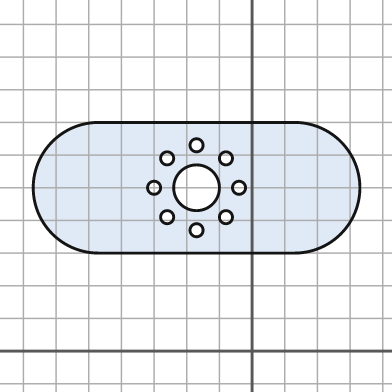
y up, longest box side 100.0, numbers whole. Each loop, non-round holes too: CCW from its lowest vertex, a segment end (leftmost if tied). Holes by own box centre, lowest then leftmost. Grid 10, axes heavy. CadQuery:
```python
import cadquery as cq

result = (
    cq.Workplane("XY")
    .moveTo(-47.0, 30.0)
    .lineTo(13.0, 30.0)
    .threePointArc((33.0, 50.0), (13.0, 70.0))
    .lineTo(-47.0, 70.0)
    .threePointArc((-67.0, 50.0), (-47.0, 30.0))
    .close()
    .moveTo(-17.0, 37.0)
    .circle(2.0)
    .moveTo(-26.0, 41.0)
    .circle(2.0)
    .moveTo(-8.0, 41.0)
    .circle(2.0)
    .moveTo(-30.0, 50.0)
    .circle(2.0)
    .moveTo(-17.0, 50.0)
    .circle(7.0)
    .moveTo(-4.0, 50.0)
    .circle(2.0)
    .moveTo(-26.0, 59.0)
    .circle(2.0)
    .moveTo(-8.0, 59.0)
    .circle(2.0)
    .moveTo(-17.0, 63.0)
    .circle(2.0)
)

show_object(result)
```